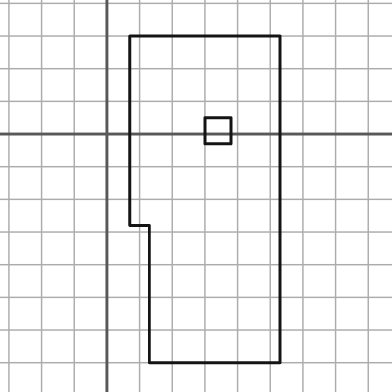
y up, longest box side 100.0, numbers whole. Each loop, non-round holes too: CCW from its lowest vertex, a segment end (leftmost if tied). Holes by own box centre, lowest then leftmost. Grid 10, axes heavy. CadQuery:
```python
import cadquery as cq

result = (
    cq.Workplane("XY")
    .moveTo(13.0, -70.0)
    .lineTo(53.0, -70.0)
    .lineTo(53.0, 30.0)
    .lineTo(7.0, 30.0)
    .lineTo(7.0, -28.0)
    .lineTo(13.0, -28.0)
    .close()
    .moveTo(30.0, -3.0)
    .lineTo(38.0, -3.0)
    .lineTo(38.0, 5.0)
    .lineTo(30.0, 5.0)
    .close()
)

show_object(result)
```